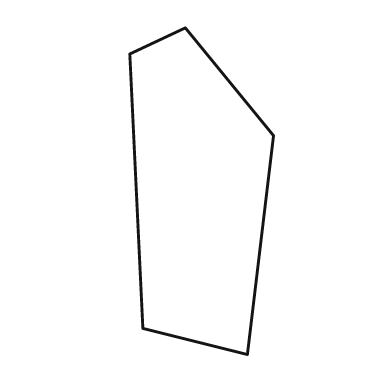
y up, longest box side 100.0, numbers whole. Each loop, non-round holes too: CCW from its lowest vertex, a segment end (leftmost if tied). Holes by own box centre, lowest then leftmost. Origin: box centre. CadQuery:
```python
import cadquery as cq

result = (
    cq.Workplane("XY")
    .moveTo(14.0, -50.0)
    .lineTo(22.0, 17.0)
    .lineTo(-5.0, 50.0)
    .lineTo(-22.0, 42.0)
    .lineTo(-18.0, -42.0)
    .close()
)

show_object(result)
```